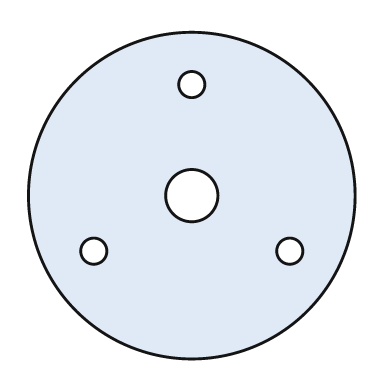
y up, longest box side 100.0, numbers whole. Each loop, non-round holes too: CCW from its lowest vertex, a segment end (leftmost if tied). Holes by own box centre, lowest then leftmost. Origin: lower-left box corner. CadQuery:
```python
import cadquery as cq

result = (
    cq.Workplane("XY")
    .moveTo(50.0, 50.0)
    .circle(50.0)
    .moveTo(20.0, 33.0)
    .circle(4.0)
    .moveTo(80.0, 33.0)
    .circle(4.0)
    .moveTo(50.0, 50.0)
    .circle(8.0)
    .moveTo(50.0, 84.0)
    .circle(4.0)
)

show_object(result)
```